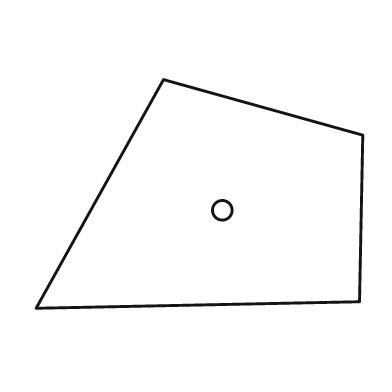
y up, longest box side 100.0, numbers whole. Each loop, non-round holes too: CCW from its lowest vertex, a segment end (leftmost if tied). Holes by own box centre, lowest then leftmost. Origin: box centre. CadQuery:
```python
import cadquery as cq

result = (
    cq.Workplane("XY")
    .moveTo(-50.0, -35.0)
    .lineTo(49.0, -33.0)
    .lineTo(50.0, 18.0)
    .lineTo(-11.0, 35.0)
    .close()
    .moveTo(7.0, -5.0)
    .circle(3.0)
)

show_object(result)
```